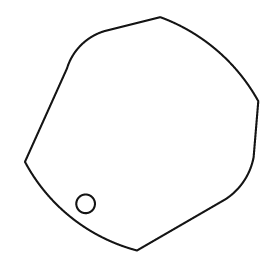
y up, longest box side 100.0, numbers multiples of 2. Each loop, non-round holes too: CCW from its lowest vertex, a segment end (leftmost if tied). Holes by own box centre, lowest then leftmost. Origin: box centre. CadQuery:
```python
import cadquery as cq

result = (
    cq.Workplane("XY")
    .moveTo(-2.0, -50.0)
    .lineTo(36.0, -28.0)
    .threePointArc((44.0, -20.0), (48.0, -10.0))
    .lineTo(50.0, 14.0)
    .threePointArc((32.0, 36.0), (8.0, 50.0))
    .lineTo(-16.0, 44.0)
    .threePointArc((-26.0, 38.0), (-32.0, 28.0))
    .lineTo(-50.0, -12.0)
    .threePointArc((-30.0, -36.0), (-2.0, -50.0))
    .close()
    .moveTo(-24.0, -30.0)
    .circle(4.0)
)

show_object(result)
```